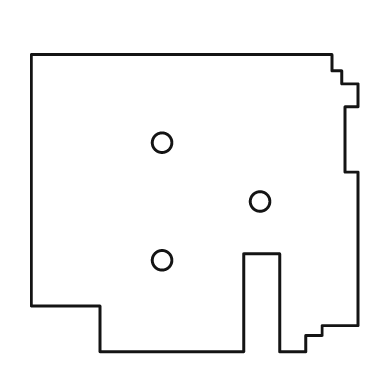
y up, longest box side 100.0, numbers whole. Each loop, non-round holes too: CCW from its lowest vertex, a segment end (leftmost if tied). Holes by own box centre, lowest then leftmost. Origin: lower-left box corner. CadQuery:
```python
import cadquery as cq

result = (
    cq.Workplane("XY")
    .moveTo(21.0, 0.0)
    .lineTo(65.0, 0.0)
    .lineTo(65.0, 30.0)
    .lineTo(76.0, 30.0)
    .lineTo(76.0, 0.0)
    .lineTo(84.0, 0.0)
    .lineTo(84.0, 5.0)
    .lineTo(89.0, 5.0)
    .lineTo(89.0, 8.0)
    .lineTo(100.0, 8.0)
    .lineTo(100.0, 55.0)
    .lineTo(96.0, 55.0)
    .lineTo(96.0, 75.0)
    .lineTo(100.0, 75.0)
    .lineTo(100.0, 82.0)
    .lineTo(95.0, 82.0)
    .lineTo(95.0, 86.0)
    .lineTo(92.0, 86.0)
    .lineTo(92.0, 91.0)
    .lineTo(0.0, 91.0)
    .lineTo(0.0, 14.0)
    .lineTo(21.0, 14.0)
    .close()
    .moveTo(40.0, 28.0)
    .circle(3.0)
    .moveTo(70.0, 46.0)
    .circle(3.0)
    .moveTo(40.0, 64.0)
    .circle(3.0)
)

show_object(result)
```